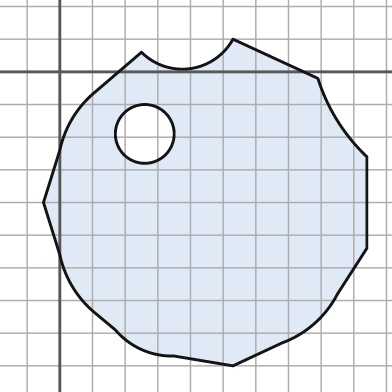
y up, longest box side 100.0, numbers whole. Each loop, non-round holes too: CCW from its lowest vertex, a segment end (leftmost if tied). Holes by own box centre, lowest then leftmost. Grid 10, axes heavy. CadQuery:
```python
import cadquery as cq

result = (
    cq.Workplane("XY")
    .moveTo(53.0, -90.0)
    .lineTo(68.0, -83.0)
    .threePointArc((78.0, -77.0), (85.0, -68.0))
    .lineTo(94.0, -54.0)
    .lineTo(94.0, -26.0)
    .threePointArc((85.0, -15.0), (79.0, -2.0))
    .lineTo(53.0, 10.0)
    .threePointArc((40.0, 1.0), (25.0, 6.0))
    .lineTo(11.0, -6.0)
    .threePointArc((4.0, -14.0), (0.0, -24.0))
    .lineTo(-5.0, -40.0)
    .lineTo(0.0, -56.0)
    .threePointArc((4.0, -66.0), (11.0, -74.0))
    .lineTo(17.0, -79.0)
    .threePointArc((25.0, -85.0), (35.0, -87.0))
    .close()
    .moveTo(26.0, -19.0)
    .circle(9.0)
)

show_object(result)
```